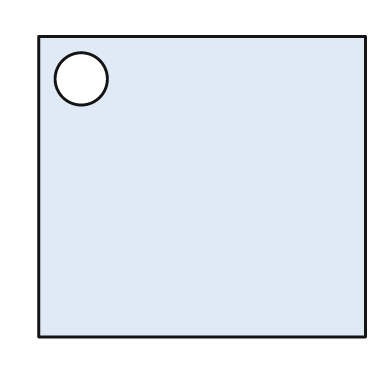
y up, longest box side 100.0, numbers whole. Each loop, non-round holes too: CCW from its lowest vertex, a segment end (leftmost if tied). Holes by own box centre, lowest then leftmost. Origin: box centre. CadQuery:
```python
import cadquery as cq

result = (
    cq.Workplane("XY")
    .moveTo(-50.0, -46.0)
    .lineTo(50.0, -46.0)
    .lineTo(50.0, 46.0)
    .lineTo(-50.0, 46.0)
    .close()
    .moveTo(-37.0, 33.0)
    .circle(8.0)
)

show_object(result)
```